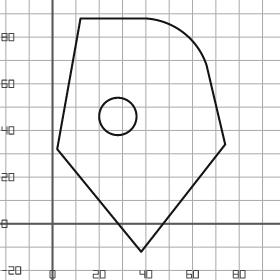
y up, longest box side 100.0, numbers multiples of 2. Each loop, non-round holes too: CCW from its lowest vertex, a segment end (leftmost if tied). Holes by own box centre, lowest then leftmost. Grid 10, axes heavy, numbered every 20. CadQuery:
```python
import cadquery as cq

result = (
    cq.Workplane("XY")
    .moveTo(38.0, -12.0)
    .lineTo(74.0, 34.0)
    .lineTo(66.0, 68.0)
    .threePointArc((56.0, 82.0), (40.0, 88.0))
    .lineTo(12.0, 88.0)
    .lineTo(2.0, 32.0)
    .close()
    .moveTo(28.0, 46.0)
    .circle(8.0)
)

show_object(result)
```